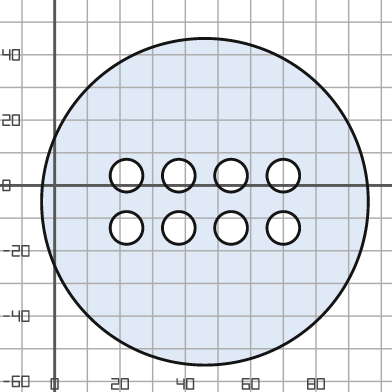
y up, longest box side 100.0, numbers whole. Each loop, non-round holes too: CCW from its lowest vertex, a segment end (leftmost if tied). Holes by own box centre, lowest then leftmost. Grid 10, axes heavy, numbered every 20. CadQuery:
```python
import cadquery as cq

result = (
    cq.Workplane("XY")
    .moveTo(46.0, -5.0)
    .circle(50.0)
    .moveTo(22.0, -13.0)
    .circle(5.0)
    .moveTo(38.0, -13.0)
    .circle(5.0)
    .moveTo(54.0, -13.0)
    .circle(5.0)
    .moveTo(70.0, -13.0)
    .circle(5.0)
    .moveTo(22.0, 3.0)
    .circle(5.0)
    .moveTo(38.0, 3.0)
    .circle(5.0)
    .moveTo(54.0, 3.0)
    .circle(5.0)
    .moveTo(70.0, 3.0)
    .circle(5.0)
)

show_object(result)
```